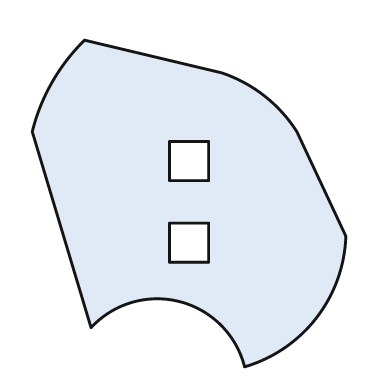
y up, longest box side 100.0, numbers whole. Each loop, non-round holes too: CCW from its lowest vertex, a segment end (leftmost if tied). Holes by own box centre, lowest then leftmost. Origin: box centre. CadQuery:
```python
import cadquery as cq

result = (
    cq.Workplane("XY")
    .moveTo(17.0, -50.0)
    .threePointArc((39.0, -35.0), (48.0, -10.0))
    .lineTo(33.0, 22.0)
    .threePointArc((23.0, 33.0), (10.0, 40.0))
    .lineTo(-32.0, 50.0)
    .threePointArc((-42.0, 37.0), (-48.0, 22.0))
    .lineTo(-30.0, -38.0)
    .threePointArc((-3.0, -30.0), (17.0, -50.0))
    .close()
    .moveTo(-6.0, -18.0)
    .lineTo(6.0, -18.0)
    .lineTo(6.0, -6.0)
    .lineTo(-6.0, -6.0)
    .close()
    .moveTo(-6.0, 7.0)
    .lineTo(6.0, 7.0)
    .lineTo(6.0, 19.0)
    .lineTo(-6.0, 19.0)
    .close()
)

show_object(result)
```